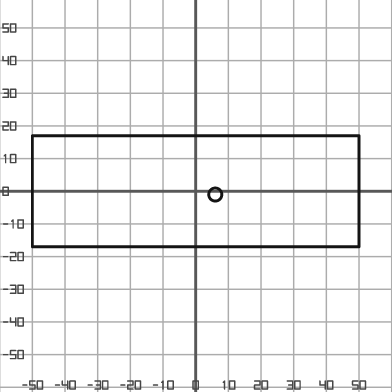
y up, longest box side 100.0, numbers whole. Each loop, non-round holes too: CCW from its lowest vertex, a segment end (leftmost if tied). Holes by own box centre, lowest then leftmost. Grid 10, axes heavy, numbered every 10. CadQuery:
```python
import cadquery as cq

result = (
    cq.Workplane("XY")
    .moveTo(-50.0, -17.0)
    .lineTo(50.0, -17.0)
    .lineTo(50.0, 17.0)
    .lineTo(-50.0, 17.0)
    .close()
    .moveTo(6.0, -1.0)
    .circle(2.0)
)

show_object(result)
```